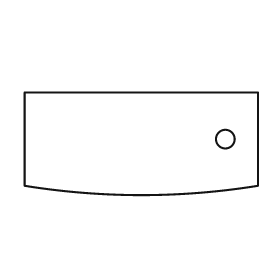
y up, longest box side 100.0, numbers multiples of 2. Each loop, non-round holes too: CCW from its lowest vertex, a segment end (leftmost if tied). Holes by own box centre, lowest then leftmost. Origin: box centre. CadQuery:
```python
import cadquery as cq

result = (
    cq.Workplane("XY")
    .moveTo(-50.0, -18.0)
    .threePointArc((0.0, -22.0), (50.0, -18.0))
    .lineTo(50.0, 22.0)
    .lineTo(-50.0, 22.0)
    .close()
    .moveTo(36.0, 2.0)
    .circle(4.0)
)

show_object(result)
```